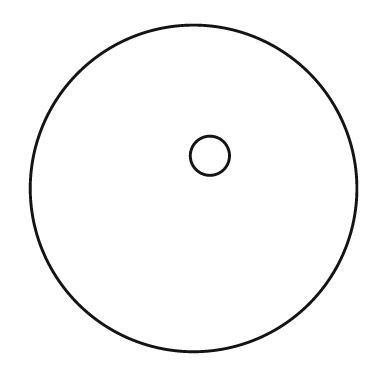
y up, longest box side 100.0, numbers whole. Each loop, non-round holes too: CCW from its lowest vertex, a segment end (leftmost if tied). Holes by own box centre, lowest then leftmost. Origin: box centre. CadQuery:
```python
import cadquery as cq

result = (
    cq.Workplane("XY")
    .moveTo(0.0, 0.0)
    .circle(50.0)
    .moveTo(5.0, 10.0)
    .circle(6.0)
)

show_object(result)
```